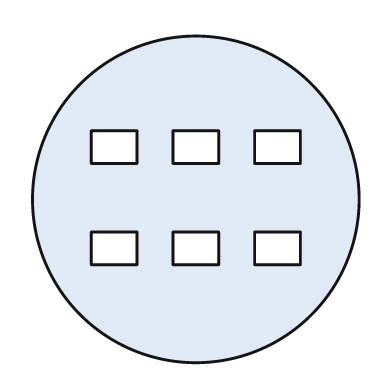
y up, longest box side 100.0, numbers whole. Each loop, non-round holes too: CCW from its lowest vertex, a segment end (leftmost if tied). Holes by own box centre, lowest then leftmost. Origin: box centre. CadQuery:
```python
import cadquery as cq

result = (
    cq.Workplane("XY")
    .moveTo(0.0, 0.0)
    .circle(50.0)
    .moveTo(-32.0, -20.0)
    .lineTo(-18.0, -20.0)
    .lineTo(-18.0, -10.0)
    .lineTo(-32.0, -10.0)
    .close()
    .moveTo(-7.0, -20.0)
    .lineTo(7.0, -20.0)
    .lineTo(7.0, -10.0)
    .lineTo(-7.0, -10.0)
    .close()
    .moveTo(18.0, -20.0)
    .lineTo(32.0, -20.0)
    .lineTo(32.0, -10.0)
    .lineTo(18.0, -10.0)
    .close()
    .moveTo(-32.0, 11.0)
    .lineTo(-18.0, 11.0)
    .lineTo(-18.0, 21.0)
    .lineTo(-32.0, 21.0)
    .close()
    .moveTo(-7.0, 11.0)
    .lineTo(7.0, 11.0)
    .lineTo(7.0, 21.0)
    .lineTo(-7.0, 21.0)
    .close()
    .moveTo(18.0, 11.0)
    .lineTo(32.0, 11.0)
    .lineTo(32.0, 21.0)
    .lineTo(18.0, 21.0)
    .close()
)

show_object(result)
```